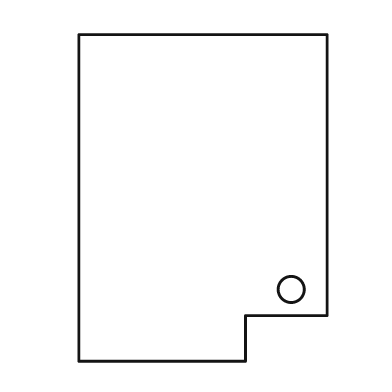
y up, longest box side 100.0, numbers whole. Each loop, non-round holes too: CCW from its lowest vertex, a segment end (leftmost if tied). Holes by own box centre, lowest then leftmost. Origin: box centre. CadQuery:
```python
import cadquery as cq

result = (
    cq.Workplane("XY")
    .moveTo(-38.0, -50.0)
    .lineTo(13.0, -50.0)
    .lineTo(13.0, -36.0)
    .lineTo(38.0, -36.0)
    .lineTo(38.0, 50.0)
    .lineTo(-38.0, 50.0)
    .close()
    .moveTo(27.0, -28.0)
    .circle(4.0)
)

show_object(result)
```